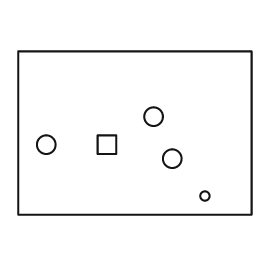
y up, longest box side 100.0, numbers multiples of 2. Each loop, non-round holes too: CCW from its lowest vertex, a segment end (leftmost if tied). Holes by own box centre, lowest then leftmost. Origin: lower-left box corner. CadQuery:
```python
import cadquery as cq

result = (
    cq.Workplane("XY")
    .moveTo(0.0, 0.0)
    .lineTo(100.0, 0.0)
    .lineTo(100.0, 70.0)
    .lineTo(0.0, 70.0)
    .close()
    .moveTo(80.0, 8.0)
    .circle(2.0)
    .moveTo(66.0, 24.0)
    .circle(4.0)
    .moveTo(12.0, 30.0)
    .circle(4.0)
    .moveTo(34.0, 26.0)
    .lineTo(42.0, 26.0)
    .lineTo(42.0, 34.0)
    .lineTo(34.0, 34.0)
    .close()
    .moveTo(58.0, 42.0)
    .circle(4.0)
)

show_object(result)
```